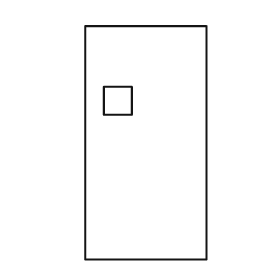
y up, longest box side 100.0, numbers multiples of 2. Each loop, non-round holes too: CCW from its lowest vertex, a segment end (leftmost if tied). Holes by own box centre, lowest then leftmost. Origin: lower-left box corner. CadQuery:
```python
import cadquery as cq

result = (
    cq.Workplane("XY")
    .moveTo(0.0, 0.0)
    .lineTo(52.0, 0.0)
    .lineTo(52.0, 100.0)
    .lineTo(0.0, 100.0)
    .close()
    .moveTo(8.0, 62.0)
    .lineTo(20.0, 62.0)
    .lineTo(20.0, 74.0)
    .lineTo(8.0, 74.0)
    .close()
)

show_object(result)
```